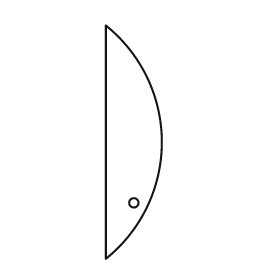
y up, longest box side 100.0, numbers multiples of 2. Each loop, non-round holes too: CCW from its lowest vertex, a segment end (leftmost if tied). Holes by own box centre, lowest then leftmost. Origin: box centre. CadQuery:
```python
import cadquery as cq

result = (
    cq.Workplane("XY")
    .moveTo(-12.0, -50.0)
    .threePointArc((12.0, 0.0), (-12.0, 50.0))
    .close()
    .moveTo(0.0, -26.0)
    .circle(2.0)
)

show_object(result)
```